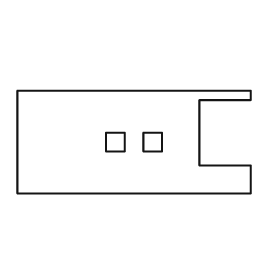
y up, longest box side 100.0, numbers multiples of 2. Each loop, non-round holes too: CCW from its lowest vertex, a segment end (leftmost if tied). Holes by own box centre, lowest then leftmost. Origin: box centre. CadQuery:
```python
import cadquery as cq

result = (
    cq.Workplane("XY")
    .moveTo(-50.0, -22.0)
    .lineTo(50.0, -22.0)
    .lineTo(50.0, -10.0)
    .lineTo(28.0, -10.0)
    .lineTo(28.0, 18.0)
    .lineTo(50.0, 18.0)
    .lineTo(50.0, 22.0)
    .lineTo(-50.0, 22.0)
    .close()
    .moveTo(-12.0, -4.0)
    .lineTo(-4.0, -4.0)
    .lineTo(-4.0, 4.0)
    .lineTo(-12.0, 4.0)
    .close()
    .moveTo(4.0, -4.0)
    .lineTo(12.0, -4.0)
    .lineTo(12.0, 4.0)
    .lineTo(4.0, 4.0)
    .close()
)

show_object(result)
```